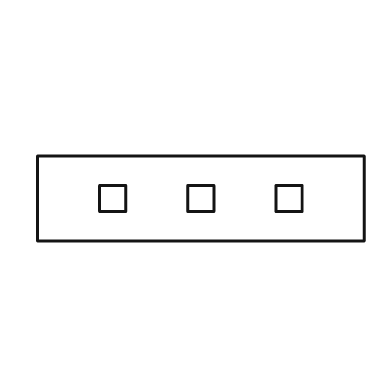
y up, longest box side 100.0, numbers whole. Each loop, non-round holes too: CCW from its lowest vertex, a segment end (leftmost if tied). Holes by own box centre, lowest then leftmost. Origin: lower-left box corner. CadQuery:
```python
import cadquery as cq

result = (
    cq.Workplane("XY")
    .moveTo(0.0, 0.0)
    .lineTo(100.0, 0.0)
    .lineTo(100.0, 26.0)
    .lineTo(0.0, 26.0)
    .close()
    .moveTo(19.0, 9.0)
    .lineTo(27.0, 9.0)
    .lineTo(27.0, 17.0)
    .lineTo(19.0, 17.0)
    .close()
    .moveTo(46.0, 9.0)
    .lineTo(54.0, 9.0)
    .lineTo(54.0, 17.0)
    .lineTo(46.0, 17.0)
    .close()
    .moveTo(73.0, 9.0)
    .lineTo(81.0, 9.0)
    .lineTo(81.0, 17.0)
    .lineTo(73.0, 17.0)
    .close()
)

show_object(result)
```